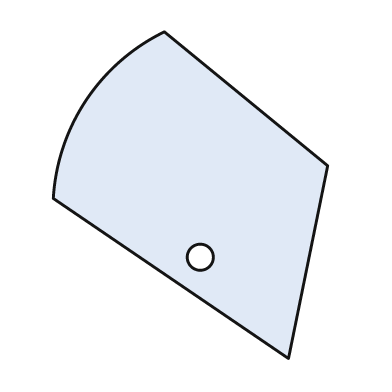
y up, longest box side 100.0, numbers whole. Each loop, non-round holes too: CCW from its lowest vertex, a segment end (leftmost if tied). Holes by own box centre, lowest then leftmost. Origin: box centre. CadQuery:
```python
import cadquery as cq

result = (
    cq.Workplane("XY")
    .moveTo(30.0, -50.0)
    .lineTo(42.0, 9.0)
    .lineTo(-8.0, 50.0)
    .threePointArc((-32.0, 29.0), (-42.0, -1.0))
    .close()
    .moveTo(3.0, -19.0)
    .circle(4.0)
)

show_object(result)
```